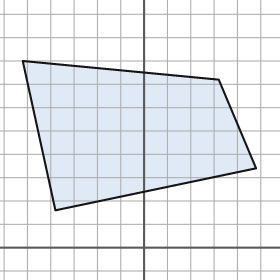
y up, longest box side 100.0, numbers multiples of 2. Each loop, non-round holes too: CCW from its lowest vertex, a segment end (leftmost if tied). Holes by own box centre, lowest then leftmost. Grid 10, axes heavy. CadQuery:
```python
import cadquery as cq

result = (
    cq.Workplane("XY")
    .moveTo(-38.0, 16.0)
    .lineTo(48.0, 34.0)
    .lineTo(32.0, 72.0)
    .lineTo(-52.0, 80.0)
    .close()
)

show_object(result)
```